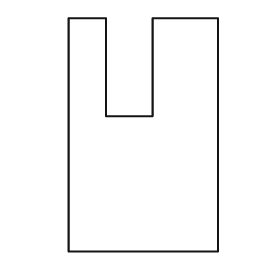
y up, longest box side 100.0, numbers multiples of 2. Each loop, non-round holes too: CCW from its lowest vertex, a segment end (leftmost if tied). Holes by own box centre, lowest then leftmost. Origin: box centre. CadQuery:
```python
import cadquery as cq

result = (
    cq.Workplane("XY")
    .moveTo(-32.0, -50.0)
    .lineTo(32.0, -50.0)
    .lineTo(32.0, 50.0)
    .lineTo(4.0, 50.0)
    .lineTo(4.0, 8.0)
    .lineTo(-16.0, 8.0)
    .lineTo(-16.0, 50.0)
    .lineTo(-32.0, 50.0)
    .close()
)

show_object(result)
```